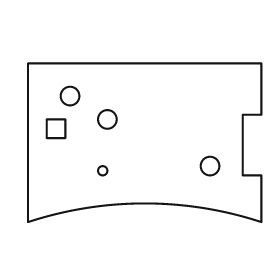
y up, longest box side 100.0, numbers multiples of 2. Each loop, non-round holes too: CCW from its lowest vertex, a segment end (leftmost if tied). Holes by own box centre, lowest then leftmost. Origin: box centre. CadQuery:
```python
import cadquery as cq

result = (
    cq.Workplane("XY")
    .moveTo(-50.0, -34.0)
    .threePointArc((0.0, -26.0), (50.0, -34.0))
    .lineTo(50.0, -14.0)
    .lineTo(42.0, -14.0)
    .lineTo(42.0, 12.0)
    .lineTo(50.0, 12.0)
    .lineTo(50.0, 34.0)
    .lineTo(-50.0, 34.0)
    .close()
    .moveTo(-18.0, -12.0)
    .circle(2.0)
    .moveTo(28.0, -10.0)
    .circle(4.0)
    .moveTo(-42.0, 2.0)
    .lineTo(-34.0, 2.0)
    .lineTo(-34.0, 10.0)
    .lineTo(-42.0, 10.0)
    .close()
    .moveTo(-16.0, 10.0)
    .circle(4.0)
    .moveTo(-32.0, 20.0)
    .circle(4.0)
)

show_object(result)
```